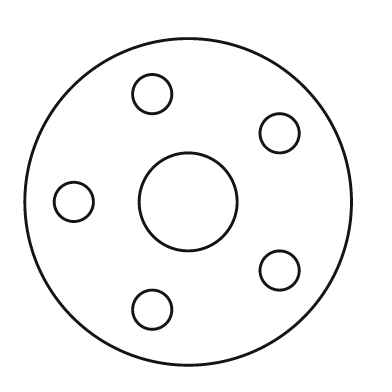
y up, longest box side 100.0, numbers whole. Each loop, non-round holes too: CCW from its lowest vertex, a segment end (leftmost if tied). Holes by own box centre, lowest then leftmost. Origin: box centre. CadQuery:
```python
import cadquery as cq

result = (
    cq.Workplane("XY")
    .moveTo(0.0, 0.0)
    .circle(50.0)
    .moveTo(-11.0, -33.0)
    .circle(6.0)
    .moveTo(28.0, -21.0)
    .circle(6.0)
    .moveTo(-35.0, 0.0)
    .circle(6.0)
    .moveTo(0.0, 0.0)
    .circle(15.0)
    .moveTo(28.0, 21.0)
    .circle(6.0)
    .moveTo(-11.0, 33.0)
    .circle(6.0)
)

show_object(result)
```